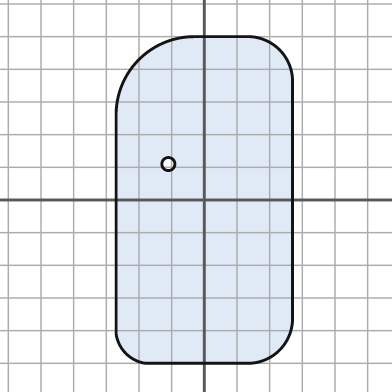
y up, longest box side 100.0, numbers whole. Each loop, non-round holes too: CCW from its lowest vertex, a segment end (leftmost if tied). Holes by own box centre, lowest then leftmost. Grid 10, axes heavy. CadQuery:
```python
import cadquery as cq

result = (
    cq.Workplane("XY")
    .moveTo(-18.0, -50.0)
    .lineTo(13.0, -50.0)
    .threePointArc((23.0, -46.0), (27.0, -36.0))
    .lineTo(27.0, 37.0)
    .threePointArc((23.0, 46.0), (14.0, 50.0))
    .lineTo(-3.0, 50.0)
    .threePointArc((-20.0, 43.0), (-27.0, 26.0))
    .lineTo(-27.0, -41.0)
    .threePointArc((-24.0, -47.0), (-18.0, -50.0))
    .close()
    .moveTo(-11.0, 11.0)
    .circle(2.0)
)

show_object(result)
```